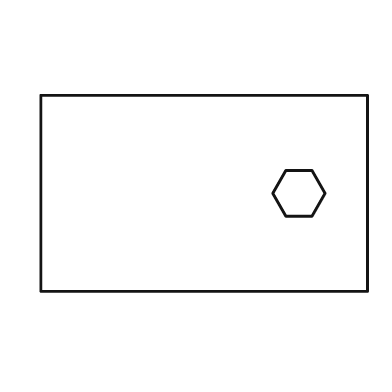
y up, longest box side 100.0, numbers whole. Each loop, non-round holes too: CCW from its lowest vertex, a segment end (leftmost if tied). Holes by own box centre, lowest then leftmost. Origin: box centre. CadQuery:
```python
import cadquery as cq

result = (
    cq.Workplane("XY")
    .moveTo(-50.0, -30.0)
    .lineTo(50.0, -30.0)
    .lineTo(50.0, 30.0)
    .lineTo(-50.0, 30.0)
    .close()
    .moveTo(25.0, -7.0)
    .lineTo(33.0, -7.0)
    .lineTo(37.0, 0.0)
    .lineTo(33.0, 7.0)
    .lineTo(25.0, 7.0)
    .lineTo(21.0, 0.0)
    .close()
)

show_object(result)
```